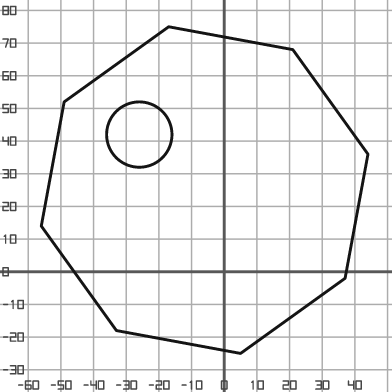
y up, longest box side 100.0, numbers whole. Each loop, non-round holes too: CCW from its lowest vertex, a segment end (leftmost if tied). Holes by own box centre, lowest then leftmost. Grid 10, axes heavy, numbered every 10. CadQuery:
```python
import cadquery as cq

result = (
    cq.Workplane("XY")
    .moveTo(5.0, -25.0)
    .lineTo(37.0, -2.0)
    .lineTo(44.0, 36.0)
    .lineTo(21.0, 68.0)
    .lineTo(-17.0, 75.0)
    .lineTo(-49.0, 52.0)
    .lineTo(-56.0, 14.0)
    .lineTo(-33.0, -18.0)
    .close()
    .moveTo(-26.0, 42.0)
    .circle(10.0)
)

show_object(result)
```